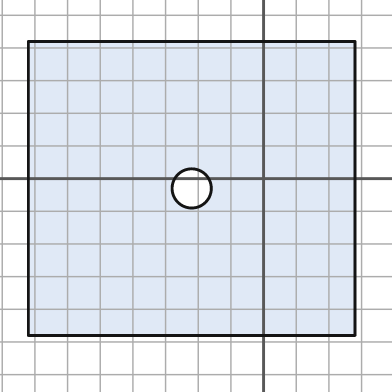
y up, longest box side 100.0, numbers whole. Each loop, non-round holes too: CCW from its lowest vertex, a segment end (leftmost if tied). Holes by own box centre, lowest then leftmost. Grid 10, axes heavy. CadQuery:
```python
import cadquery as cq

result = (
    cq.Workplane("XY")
    .moveTo(-72.0, -48.0)
    .lineTo(28.0, -48.0)
    .lineTo(28.0, 42.0)
    .lineTo(-72.0, 42.0)
    .close()
    .moveTo(-22.0, -3.0)
    .circle(6.0)
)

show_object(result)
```